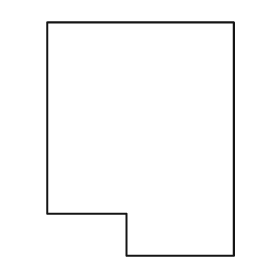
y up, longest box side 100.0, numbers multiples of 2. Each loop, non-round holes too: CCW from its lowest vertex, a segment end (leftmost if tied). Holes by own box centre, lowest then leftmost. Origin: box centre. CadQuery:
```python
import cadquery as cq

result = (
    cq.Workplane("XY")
    .moveTo(-6.0, -50.0)
    .lineTo(40.0, -50.0)
    .lineTo(40.0, 50.0)
    .lineTo(-40.0, 50.0)
    .lineTo(-40.0, -32.0)
    .lineTo(-6.0, -32.0)
    .close()
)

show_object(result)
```